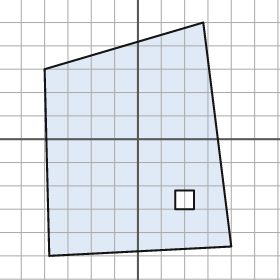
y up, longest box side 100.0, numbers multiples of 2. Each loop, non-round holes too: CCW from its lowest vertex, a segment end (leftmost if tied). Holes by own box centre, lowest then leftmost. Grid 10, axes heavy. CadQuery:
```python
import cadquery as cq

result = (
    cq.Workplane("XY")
    .moveTo(-38.0, -50.0)
    .lineTo(40.0, -46.0)
    .lineTo(28.0, 50.0)
    .lineTo(-40.0, 30.0)
    .close()
    .moveTo(16.0, -30.0)
    .lineTo(24.0, -30.0)
    .lineTo(24.0, -22.0)
    .lineTo(16.0, -22.0)
    .close()
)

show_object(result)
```